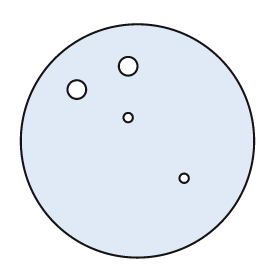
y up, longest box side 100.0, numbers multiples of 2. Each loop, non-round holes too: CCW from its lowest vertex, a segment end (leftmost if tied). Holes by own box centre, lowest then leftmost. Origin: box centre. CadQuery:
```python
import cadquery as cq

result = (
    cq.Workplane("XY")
    .moveTo(0.0, 0.0)
    .circle(50.0)
    .moveTo(20.0, -16.0)
    .circle(2.0)
    .moveTo(-4.0, 10.0)
    .circle(2.0)
    .moveTo(-26.0, 22.0)
    .circle(4.0)
    .moveTo(-4.0, 32.0)
    .circle(4.0)
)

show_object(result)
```